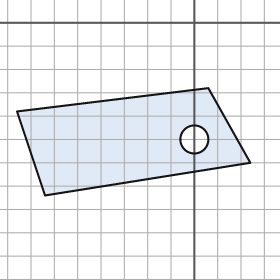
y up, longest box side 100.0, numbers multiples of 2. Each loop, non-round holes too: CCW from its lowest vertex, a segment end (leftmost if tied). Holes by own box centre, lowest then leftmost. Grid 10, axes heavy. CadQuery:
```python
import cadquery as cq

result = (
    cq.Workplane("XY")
    .moveTo(-64.0, -74.0)
    .lineTo(24.0, -60.0)
    .lineTo(6.0, -28.0)
    .lineTo(-76.0, -38.0)
    .close()
    .moveTo(0.0, -50.0)
    .circle(6.0)
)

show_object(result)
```